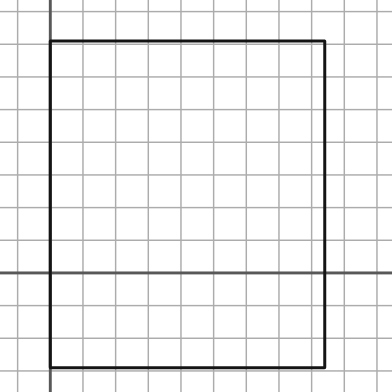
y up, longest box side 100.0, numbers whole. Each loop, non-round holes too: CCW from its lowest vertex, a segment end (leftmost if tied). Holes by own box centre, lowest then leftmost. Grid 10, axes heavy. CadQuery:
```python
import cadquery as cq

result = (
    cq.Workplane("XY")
    .moveTo(0.0, -29.0)
    .lineTo(84.0, -29.0)
    .lineTo(84.0, 71.0)
    .lineTo(0.0, 71.0)
    .close()
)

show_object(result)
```